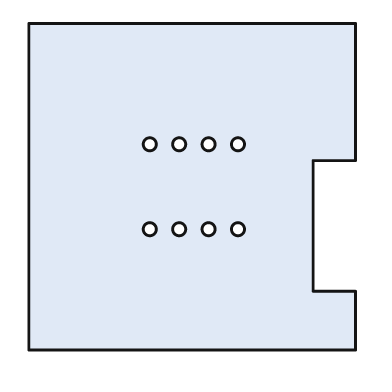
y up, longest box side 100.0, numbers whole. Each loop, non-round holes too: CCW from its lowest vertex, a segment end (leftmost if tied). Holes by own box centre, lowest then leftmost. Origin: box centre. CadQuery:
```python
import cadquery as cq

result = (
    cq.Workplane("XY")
    .moveTo(-50.0, -50.0)
    .lineTo(50.0, -50.0)
    .lineTo(50.0, -32.0)
    .lineTo(37.0, -32.0)
    .lineTo(37.0, 8.0)
    .lineTo(50.0, 8.0)
    .lineTo(50.0, 50.0)
    .lineTo(-50.0, 50.0)
    .close()
    .moveTo(-13.0, -13.0)
    .circle(2.0)
    .moveTo(-4.0, -13.0)
    .circle(2.0)
    .moveTo(5.0, -13.0)
    .circle(2.0)
    .moveTo(14.0, -13.0)
    .circle(2.0)
    .moveTo(-13.0, 13.0)
    .circle(2.0)
    .moveTo(-4.0, 13.0)
    .circle(2.0)
    .moveTo(5.0, 13.0)
    .circle(2.0)
    .moveTo(14.0, 13.0)
    .circle(2.0)
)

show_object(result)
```